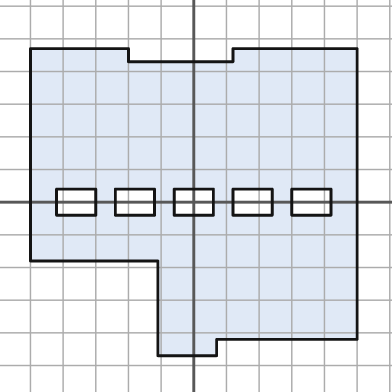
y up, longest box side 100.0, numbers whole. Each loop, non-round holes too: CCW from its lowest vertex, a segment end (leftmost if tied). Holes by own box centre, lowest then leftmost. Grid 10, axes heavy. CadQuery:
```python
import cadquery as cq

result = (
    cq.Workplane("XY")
    .moveTo(-11.0, -47.0)
    .lineTo(7.0, -47.0)
    .lineTo(7.0, -42.0)
    .lineTo(50.0, -42.0)
    .lineTo(50.0, 47.0)
    .lineTo(12.0, 47.0)
    .lineTo(12.0, 43.0)
    .lineTo(-20.0, 43.0)
    .lineTo(-20.0, 47.0)
    .lineTo(-50.0, 47.0)
    .lineTo(-50.0, -18.0)
    .lineTo(-11.0, -18.0)
    .close()
    .moveTo(-42.0, -4.0)
    .lineTo(-30.0, -4.0)
    .lineTo(-30.0, 4.0)
    .lineTo(-42.0, 4.0)
    .close()
    .moveTo(-24.0, -4.0)
    .lineTo(-12.0, -4.0)
    .lineTo(-12.0, 4.0)
    .lineTo(-24.0, 4.0)
    .close()
    .moveTo(-6.0, -4.0)
    .lineTo(6.0, -4.0)
    .lineTo(6.0, 4.0)
    .lineTo(-6.0, 4.0)
    .close()
    .moveTo(12.0, -4.0)
    .lineTo(24.0, -4.0)
    .lineTo(24.0, 4.0)
    .lineTo(12.0, 4.0)
    .close()
    .moveTo(30.0, -4.0)
    .lineTo(42.0, -4.0)
    .lineTo(42.0, 4.0)
    .lineTo(30.0, 4.0)
    .close()
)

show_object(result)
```